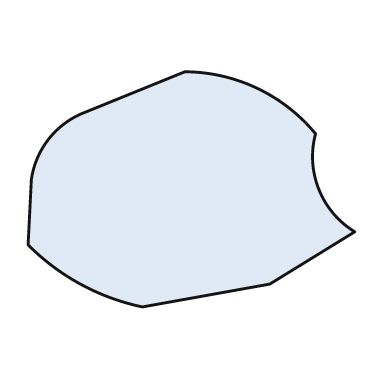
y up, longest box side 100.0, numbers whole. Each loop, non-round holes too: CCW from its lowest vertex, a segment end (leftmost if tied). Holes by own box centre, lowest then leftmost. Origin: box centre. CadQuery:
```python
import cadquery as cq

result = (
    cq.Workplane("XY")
    .moveTo(-15.0, -36.0)
    .lineTo(24.0, -29.0)
    .lineTo(50.0, -13.0)
    .threePointArc((39.0, 0.0), (38.0, 17.0))
    .threePointArc((20.0, 31.0), (-2.0, 36.0))
    .lineTo(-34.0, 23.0)
    .threePointArc((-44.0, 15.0), (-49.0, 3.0))
    .lineTo(-50.0, -17.0)
    .threePointArc((-34.0, -29.0), (-15.0, -36.0))
    .close()
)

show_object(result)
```